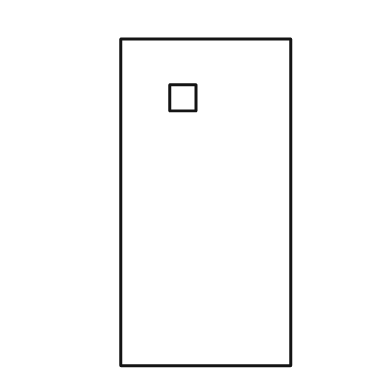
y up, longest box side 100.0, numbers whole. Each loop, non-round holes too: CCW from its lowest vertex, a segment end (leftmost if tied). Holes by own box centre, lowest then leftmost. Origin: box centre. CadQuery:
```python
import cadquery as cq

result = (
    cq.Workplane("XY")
    .moveTo(-26.0, -50.0)
    .lineTo(26.0, -50.0)
    .lineTo(26.0, 50.0)
    .lineTo(-26.0, 50.0)
    .close()
    .moveTo(-11.0, 28.0)
    .lineTo(-3.0, 28.0)
    .lineTo(-3.0, 36.0)
    .lineTo(-11.0, 36.0)
    .close()
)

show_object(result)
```